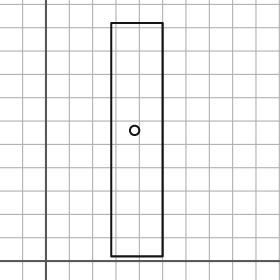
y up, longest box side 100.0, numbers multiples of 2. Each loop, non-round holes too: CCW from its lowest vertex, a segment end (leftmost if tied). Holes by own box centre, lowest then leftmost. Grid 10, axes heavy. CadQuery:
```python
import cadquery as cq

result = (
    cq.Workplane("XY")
    .moveTo(28.0, 2.0)
    .lineTo(50.0, 2.0)
    .lineTo(50.0, 102.0)
    .lineTo(28.0, 102.0)
    .close()
    .moveTo(38.0, 56.0)
    .circle(2.0)
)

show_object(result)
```